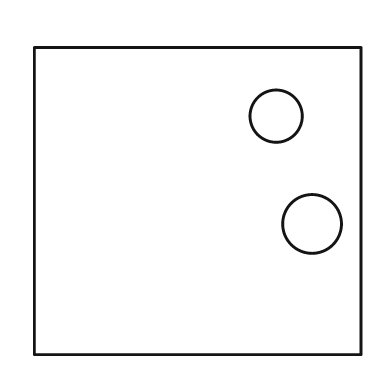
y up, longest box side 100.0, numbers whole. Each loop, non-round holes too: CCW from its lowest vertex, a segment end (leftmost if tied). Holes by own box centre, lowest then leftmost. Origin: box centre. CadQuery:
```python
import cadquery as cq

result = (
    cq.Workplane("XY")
    .moveTo(-50.0, -47.0)
    .lineTo(50.0, -47.0)
    .lineTo(50.0, 47.0)
    .lineTo(-50.0, 47.0)
    .close()
    .moveTo(35.0, -7.0)
    .circle(9.0)
    .moveTo(24.0, 26.0)
    .circle(8.0)
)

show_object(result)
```